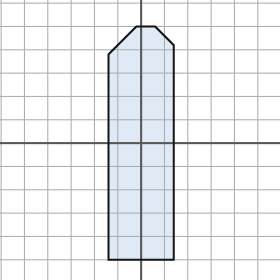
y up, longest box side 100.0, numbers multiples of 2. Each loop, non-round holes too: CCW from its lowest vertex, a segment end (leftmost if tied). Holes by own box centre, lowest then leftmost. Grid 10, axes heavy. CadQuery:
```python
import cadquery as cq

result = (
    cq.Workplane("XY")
    .moveTo(-14.0, -50.0)
    .lineTo(14.0, -50.0)
    .lineTo(14.0, 42.0)
    .lineTo(6.0, 50.0)
    .lineTo(-2.0, 50.0)
    .lineTo(-14.0, 38.0)
    .close()
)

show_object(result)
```